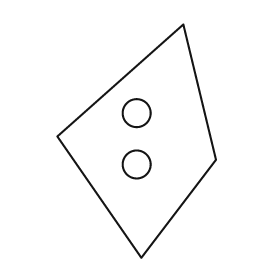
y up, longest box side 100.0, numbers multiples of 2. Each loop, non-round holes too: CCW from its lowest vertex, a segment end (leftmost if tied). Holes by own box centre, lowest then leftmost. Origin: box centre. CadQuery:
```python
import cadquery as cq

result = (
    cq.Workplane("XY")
    .moveTo(2.0, -50.0)
    .lineTo(34.0, -8.0)
    .lineTo(20.0, 50.0)
    .lineTo(-34.0, 2.0)
    .close()
    .moveTo(0.0, -10.0)
    .circle(6.0)
    .moveTo(0.0, 12.0)
    .circle(6.0)
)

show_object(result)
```